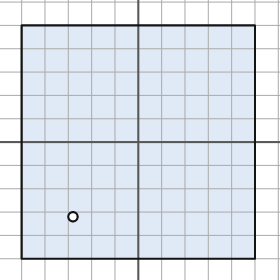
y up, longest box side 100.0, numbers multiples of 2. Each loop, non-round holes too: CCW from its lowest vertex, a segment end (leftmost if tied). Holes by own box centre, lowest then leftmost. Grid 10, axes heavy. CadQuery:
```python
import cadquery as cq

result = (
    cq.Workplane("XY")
    .moveTo(-50.0, -50.0)
    .lineTo(50.0, -50.0)
    .lineTo(50.0, 50.0)
    .lineTo(-50.0, 50.0)
    .close()
    .moveTo(-28.0, -32.0)
    .circle(2.0)
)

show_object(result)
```